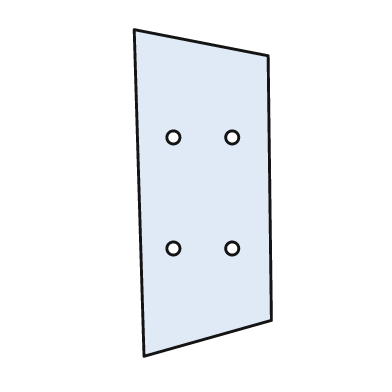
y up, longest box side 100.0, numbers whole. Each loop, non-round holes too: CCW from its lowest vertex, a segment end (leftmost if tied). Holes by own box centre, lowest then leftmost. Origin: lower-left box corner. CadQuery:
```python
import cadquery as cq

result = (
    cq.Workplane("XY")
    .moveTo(3.0, 0.0)
    .lineTo(42.0, 11.0)
    .lineTo(41.0, 92.0)
    .lineTo(0.0, 100.0)
    .close()
    .moveTo(12.0, 33.0)
    .circle(2.0)
    .moveTo(30.0, 33.0)
    .circle(2.0)
    .moveTo(12.0, 67.0)
    .circle(2.0)
    .moveTo(30.0, 67.0)
    .circle(2.0)
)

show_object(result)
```